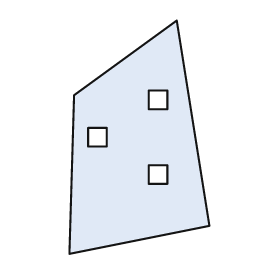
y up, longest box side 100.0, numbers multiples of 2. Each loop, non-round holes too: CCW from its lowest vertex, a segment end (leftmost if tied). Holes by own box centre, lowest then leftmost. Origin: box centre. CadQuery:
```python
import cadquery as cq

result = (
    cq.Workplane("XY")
    .moveTo(-30.0, -50.0)
    .lineTo(30.0, -38.0)
    .lineTo(16.0, 50.0)
    .lineTo(-28.0, 18.0)
    .close()
    .moveTo(4.0, -20.0)
    .lineTo(12.0, -20.0)
    .lineTo(12.0, -12.0)
    .lineTo(4.0, -12.0)
    .close()
    .moveTo(-22.0, -4.0)
    .lineTo(-14.0, -4.0)
    .lineTo(-14.0, 4.0)
    .lineTo(-22.0, 4.0)
    .close()
    .moveTo(4.0, 12.0)
    .lineTo(12.0, 12.0)
    .lineTo(12.0, 20.0)
    .lineTo(4.0, 20.0)
    .close()
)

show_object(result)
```